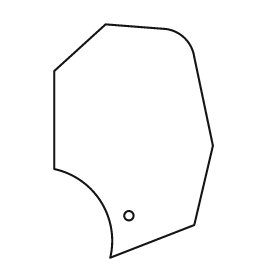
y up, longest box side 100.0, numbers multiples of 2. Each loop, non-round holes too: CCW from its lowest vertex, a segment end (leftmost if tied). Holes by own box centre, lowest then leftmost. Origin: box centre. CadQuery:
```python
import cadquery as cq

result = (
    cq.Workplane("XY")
    .moveTo(-10.0, -50.0)
    .lineTo(26.0, -36.0)
    .lineTo(34.0, -2.0)
    .lineTo(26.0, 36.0)
    .threePointArc((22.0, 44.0), (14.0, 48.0))
    .lineTo(-12.0, 50.0)
    .lineTo(-34.0, 30.0)
    .lineTo(-34.0, -12.0)
    .threePointArc((-14.0, -26.0), (-10.0, -50.0))
    .close()
    .moveTo(-2.0, -32.0)
    .circle(2.0)
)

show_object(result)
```